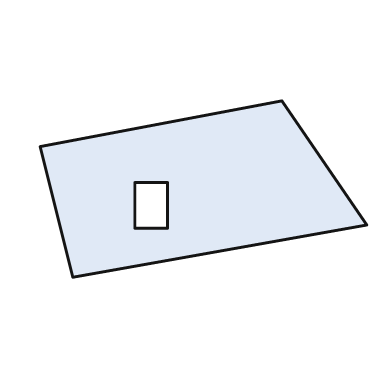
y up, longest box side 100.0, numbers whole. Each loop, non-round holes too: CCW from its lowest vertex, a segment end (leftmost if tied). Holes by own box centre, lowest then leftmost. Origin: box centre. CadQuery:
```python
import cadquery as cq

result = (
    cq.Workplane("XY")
    .moveTo(-40.0, -27.0)
    .lineTo(50.0, -11.0)
    .lineTo(24.0, 27.0)
    .lineTo(-50.0, 13.0)
    .close()
    .moveTo(-21.0, -12.0)
    .lineTo(-11.0, -12.0)
    .lineTo(-11.0, 2.0)
    .lineTo(-21.0, 2.0)
    .close()
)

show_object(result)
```